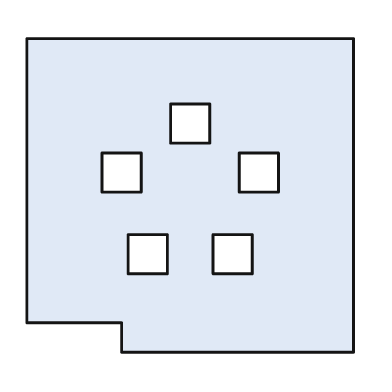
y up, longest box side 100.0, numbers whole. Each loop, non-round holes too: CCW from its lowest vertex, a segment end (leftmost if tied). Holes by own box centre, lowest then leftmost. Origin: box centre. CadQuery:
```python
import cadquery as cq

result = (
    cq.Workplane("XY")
    .moveTo(-21.0, -48.0)
    .lineTo(50.0, -48.0)
    .lineTo(50.0, 48.0)
    .lineTo(-50.0, 48.0)
    .lineTo(-50.0, -39.0)
    .lineTo(-21.0, -39.0)
    .close()
    .moveTo(-19.0, -24.0)
    .lineTo(-7.0, -24.0)
    .lineTo(-7.0, -12.0)
    .lineTo(-19.0, -12.0)
    .close()
    .moveTo(7.0, -24.0)
    .lineTo(19.0, -24.0)
    .lineTo(19.0, -12.0)
    .lineTo(7.0, -12.0)
    .close()
    .moveTo(-27.0, 1.0)
    .lineTo(-15.0, 1.0)
    .lineTo(-15.0, 13.0)
    .lineTo(-27.0, 13.0)
    .close()
    .moveTo(15.0, 1.0)
    .lineTo(27.0, 1.0)
    .lineTo(27.0, 13.0)
    .lineTo(15.0, 13.0)
    .close()
    .moveTo(-6.0, 16.0)
    .lineTo(6.0, 16.0)
    .lineTo(6.0, 28.0)
    .lineTo(-6.0, 28.0)
    .close()
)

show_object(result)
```